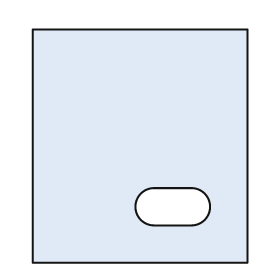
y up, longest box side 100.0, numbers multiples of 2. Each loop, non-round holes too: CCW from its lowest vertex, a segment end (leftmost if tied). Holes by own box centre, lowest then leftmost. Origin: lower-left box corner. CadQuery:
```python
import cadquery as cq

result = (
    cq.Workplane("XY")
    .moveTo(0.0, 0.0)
    .lineTo(92.0, 0.0)
    .lineTo(92.0, 100.0)
    .lineTo(0.0, 100.0)
    .close()
    .moveTo(52.0, 16.0)
    .lineTo(68.0, 16.0)
    .threePointArc((76.0, 24.0), (68.0, 32.0))
    .lineTo(52.0, 32.0)
    .threePointArc((44.0, 24.0), (52.0, 16.0))
    .close()
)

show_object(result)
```